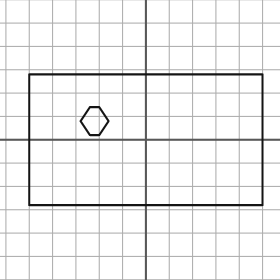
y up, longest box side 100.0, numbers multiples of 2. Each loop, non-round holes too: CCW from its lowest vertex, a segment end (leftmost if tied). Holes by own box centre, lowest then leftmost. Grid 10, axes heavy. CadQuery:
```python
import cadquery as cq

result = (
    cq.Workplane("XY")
    .moveTo(-50.0, -28.0)
    .lineTo(50.0, -28.0)
    .lineTo(50.0, 28.0)
    .lineTo(-50.0, 28.0)
    .close()
    .moveTo(-24.0, 2.0)
    .lineTo(-20.0, 2.0)
    .lineTo(-16.0, 8.0)
    .lineTo(-20.0, 14.0)
    .lineTo(-24.0, 14.0)
    .lineTo(-28.0, 8.0)
    .close()
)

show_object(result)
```